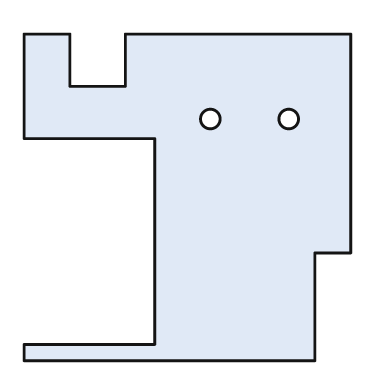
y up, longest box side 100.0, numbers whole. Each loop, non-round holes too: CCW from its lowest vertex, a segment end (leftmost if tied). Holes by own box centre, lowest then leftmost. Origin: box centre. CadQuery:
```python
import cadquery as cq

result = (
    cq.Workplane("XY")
    .moveTo(-50.0, -50.0)
    .lineTo(39.0, -50.0)
    .lineTo(39.0, -17.0)
    .lineTo(50.0, -17.0)
    .lineTo(50.0, 50.0)
    .lineTo(-19.0, 50.0)
    .lineTo(-19.0, 34.0)
    .lineTo(-36.0, 34.0)
    .lineTo(-36.0, 50.0)
    .lineTo(-50.0, 50.0)
    .lineTo(-50.0, 18.0)
    .lineTo(-10.0, 18.0)
    .lineTo(-10.0, -45.0)
    .lineTo(-50.0, -45.0)
    .close()
    .moveTo(7.0, 24.0)
    .circle(3.0)
    .moveTo(31.0, 24.0)
    .circle(3.0)
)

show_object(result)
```